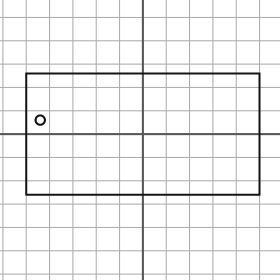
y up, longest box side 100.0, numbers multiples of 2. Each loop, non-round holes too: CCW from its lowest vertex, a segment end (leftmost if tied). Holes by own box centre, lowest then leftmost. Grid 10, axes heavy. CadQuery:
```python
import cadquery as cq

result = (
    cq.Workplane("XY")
    .moveTo(-50.0, -26.0)
    .lineTo(50.0, -26.0)
    .lineTo(50.0, 26.0)
    .lineTo(-50.0, 26.0)
    .close()
    .moveTo(-44.0, 6.0)
    .circle(2.0)
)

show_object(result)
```